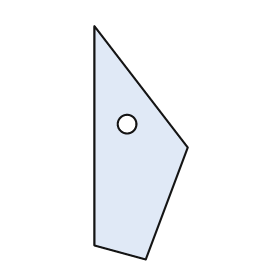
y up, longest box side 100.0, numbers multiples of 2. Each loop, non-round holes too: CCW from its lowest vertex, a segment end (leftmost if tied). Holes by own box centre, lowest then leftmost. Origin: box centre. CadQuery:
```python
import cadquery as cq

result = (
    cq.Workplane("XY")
    .moveTo(2.0, -50.0)
    .lineTo(20.0, -2.0)
    .lineTo(-20.0, 50.0)
    .lineTo(-20.0, -44.0)
    .close()
    .moveTo(-6.0, 8.0)
    .circle(4.0)
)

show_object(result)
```